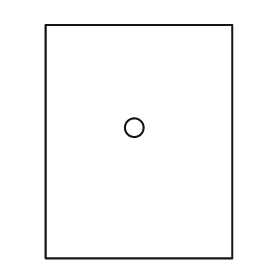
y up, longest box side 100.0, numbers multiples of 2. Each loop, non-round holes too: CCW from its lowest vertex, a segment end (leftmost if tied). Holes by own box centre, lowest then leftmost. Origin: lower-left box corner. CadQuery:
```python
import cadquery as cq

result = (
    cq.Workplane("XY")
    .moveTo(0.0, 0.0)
    .lineTo(80.0, 0.0)
    .lineTo(80.0, 100.0)
    .lineTo(0.0, 100.0)
    .close()
    .moveTo(38.0, 56.0)
    .circle(4.0)
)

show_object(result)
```